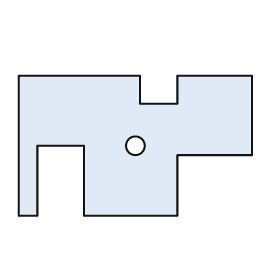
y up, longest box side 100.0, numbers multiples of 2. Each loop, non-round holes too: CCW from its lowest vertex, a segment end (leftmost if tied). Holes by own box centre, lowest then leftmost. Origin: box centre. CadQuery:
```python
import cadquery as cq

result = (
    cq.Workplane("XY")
    .moveTo(-50.0, -30.0)
    .lineTo(-42.0, -30.0)
    .lineTo(-42.0, 0.0)
    .lineTo(-22.0, 0.0)
    .lineTo(-22.0, -30.0)
    .lineTo(18.0, -30.0)
    .lineTo(18.0, -4.0)
    .lineTo(50.0, -4.0)
    .lineTo(50.0, 30.0)
    .lineTo(18.0, 30.0)
    .lineTo(18.0, 18.0)
    .lineTo(2.0, 18.0)
    .lineTo(2.0, 30.0)
    .lineTo(-50.0, 30.0)
    .close()
    .moveTo(0.0, 0.0)
    .circle(4.0)
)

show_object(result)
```